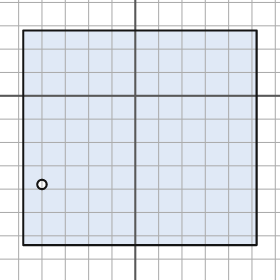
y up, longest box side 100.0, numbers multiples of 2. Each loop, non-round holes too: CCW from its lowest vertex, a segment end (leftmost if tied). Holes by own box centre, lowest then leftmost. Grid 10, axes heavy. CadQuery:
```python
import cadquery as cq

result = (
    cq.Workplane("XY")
    .moveTo(-48.0, -64.0)
    .lineTo(52.0, -64.0)
    .lineTo(52.0, 28.0)
    .lineTo(-48.0, 28.0)
    .close()
    .moveTo(-40.0, -38.0)
    .circle(2.0)
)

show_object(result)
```